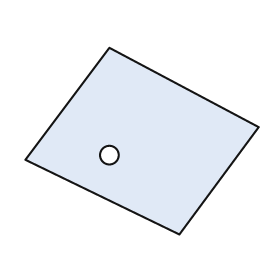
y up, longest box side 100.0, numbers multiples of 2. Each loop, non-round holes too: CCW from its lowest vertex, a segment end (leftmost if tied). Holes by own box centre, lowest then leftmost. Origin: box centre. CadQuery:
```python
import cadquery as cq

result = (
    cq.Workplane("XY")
    .moveTo(16.0, -40.0)
    .lineTo(50.0, 6.0)
    .lineTo(-14.0, 40.0)
    .lineTo(-50.0, -8.0)
    .close()
    .moveTo(-14.0, -6.0)
    .circle(4.0)
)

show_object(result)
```